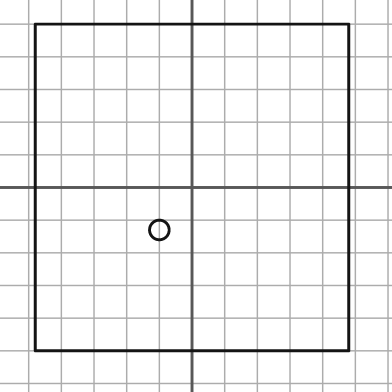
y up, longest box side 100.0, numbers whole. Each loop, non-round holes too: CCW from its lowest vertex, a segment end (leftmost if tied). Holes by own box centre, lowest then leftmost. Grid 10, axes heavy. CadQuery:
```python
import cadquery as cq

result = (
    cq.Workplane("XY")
    .moveTo(-48.0, -50.0)
    .lineTo(48.0, -50.0)
    .lineTo(48.0, 50.0)
    .lineTo(-48.0, 50.0)
    .close()
    .moveTo(-10.0, -13.0)
    .circle(3.0)
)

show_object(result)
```